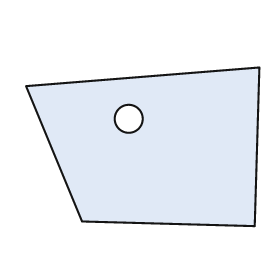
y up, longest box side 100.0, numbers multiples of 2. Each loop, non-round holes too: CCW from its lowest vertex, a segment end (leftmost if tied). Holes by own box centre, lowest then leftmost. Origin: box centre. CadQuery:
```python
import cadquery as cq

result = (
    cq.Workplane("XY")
    .moveTo(48.0, -34.0)
    .lineTo(50.0, 34.0)
    .lineTo(-50.0, 26.0)
    .lineTo(-26.0, -32.0)
    .close()
    .moveTo(-6.0, 12.0)
    .circle(6.0)
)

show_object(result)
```